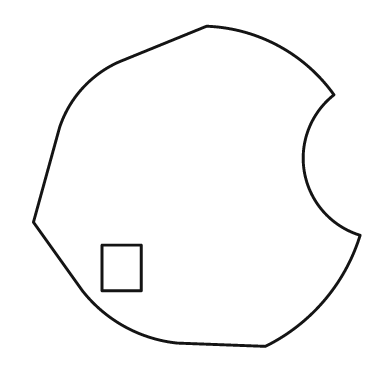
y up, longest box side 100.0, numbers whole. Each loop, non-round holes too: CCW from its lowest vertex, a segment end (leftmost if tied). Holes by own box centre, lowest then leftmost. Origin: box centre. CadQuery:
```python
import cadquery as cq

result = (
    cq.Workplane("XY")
    .moveTo(21.0, -49.0)
    .threePointArc((39.0, -35.0), (50.0, -15.0))
    .threePointArc((33.0, 4.0), (42.0, 28.0))
    .threePointArc((25.0, 43.0), (3.0, 49.0))
    .lineTo(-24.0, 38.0)
    .threePointArc((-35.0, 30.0), (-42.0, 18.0))
    .lineTo(-50.0, -11.0)
    .lineTo(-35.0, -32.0)
    .threePointArc((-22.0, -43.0), (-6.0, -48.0))
    .close()
    .moveTo(-29.0, -32.0)
    .lineTo(-17.0, -32.0)
    .lineTo(-17.0, -18.0)
    .lineTo(-29.0, -18.0)
    .close()
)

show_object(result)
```